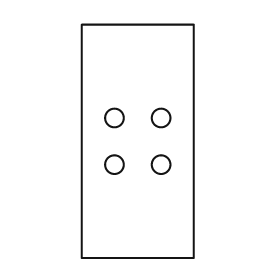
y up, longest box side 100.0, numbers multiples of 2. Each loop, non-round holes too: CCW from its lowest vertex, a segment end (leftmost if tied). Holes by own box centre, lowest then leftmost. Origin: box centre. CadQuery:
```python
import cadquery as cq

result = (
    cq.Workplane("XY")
    .moveTo(-24.0, -50.0)
    .lineTo(24.0, -50.0)
    .lineTo(24.0, 50.0)
    .lineTo(-24.0, 50.0)
    .close()
    .moveTo(-10.0, -10.0)
    .circle(4.0)
    .moveTo(10.0, -10.0)
    .circle(4.0)
    .moveTo(-10.0, 10.0)
    .circle(4.0)
    .moveTo(10.0, 10.0)
    .circle(4.0)
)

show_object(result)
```